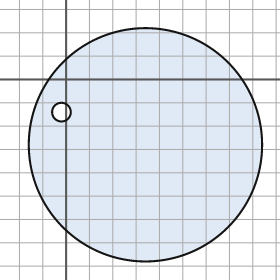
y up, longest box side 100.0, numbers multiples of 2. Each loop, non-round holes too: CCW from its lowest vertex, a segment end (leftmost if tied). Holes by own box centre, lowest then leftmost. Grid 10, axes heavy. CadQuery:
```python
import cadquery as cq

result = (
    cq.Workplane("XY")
    .moveTo(34.0, -28.0)
    .circle(50.0)
    .moveTo(-2.0, -14.0)
    .circle(4.0)
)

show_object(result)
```